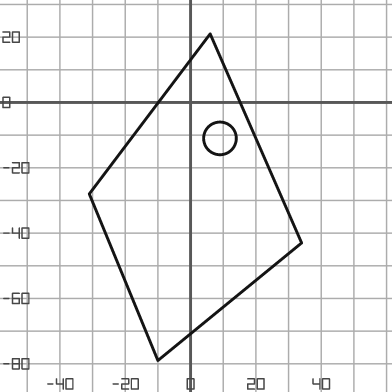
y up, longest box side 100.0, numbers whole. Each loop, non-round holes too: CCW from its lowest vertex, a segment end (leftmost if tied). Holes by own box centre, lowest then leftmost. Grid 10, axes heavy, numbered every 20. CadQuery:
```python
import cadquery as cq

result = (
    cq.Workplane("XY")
    .moveTo(-10.0, -79.0)
    .lineTo(34.0, -43.0)
    .lineTo(6.0, 21.0)
    .lineTo(-31.0, -28.0)
    .close()
    .moveTo(9.0, -11.0)
    .circle(5.0)
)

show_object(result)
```